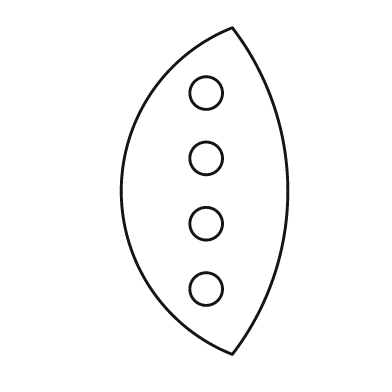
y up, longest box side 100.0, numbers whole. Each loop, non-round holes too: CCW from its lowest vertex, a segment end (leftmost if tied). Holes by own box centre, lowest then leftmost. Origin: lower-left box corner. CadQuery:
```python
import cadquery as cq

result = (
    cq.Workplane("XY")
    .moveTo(34.0, 0.0)
    .threePointArc((51.0, 50.0), (34.0, 100.0))
    .threePointArc((0.0, 50.0), (34.0, 0.0))
    .close()
    .moveTo(26.0, 20.0)
    .circle(5.0)
    .moveTo(26.0, 40.0)
    .circle(5.0)
    .moveTo(26.0, 60.0)
    .circle(5.0)
    .moveTo(26.0, 80.0)
    .circle(5.0)
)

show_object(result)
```